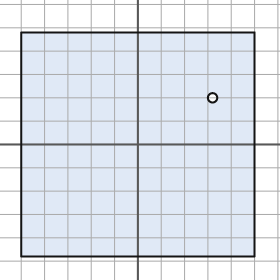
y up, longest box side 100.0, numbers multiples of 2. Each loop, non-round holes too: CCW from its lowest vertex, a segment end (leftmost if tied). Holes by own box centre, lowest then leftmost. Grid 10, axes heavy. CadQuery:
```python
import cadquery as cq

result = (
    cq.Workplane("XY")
    .moveTo(-50.0, -48.0)
    .lineTo(50.0, -48.0)
    .lineTo(50.0, 48.0)
    .lineTo(-50.0, 48.0)
    .close()
    .moveTo(32.0, 20.0)
    .circle(2.0)
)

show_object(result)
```